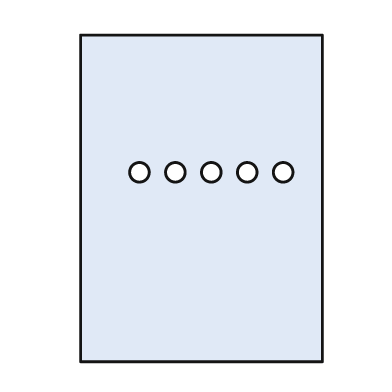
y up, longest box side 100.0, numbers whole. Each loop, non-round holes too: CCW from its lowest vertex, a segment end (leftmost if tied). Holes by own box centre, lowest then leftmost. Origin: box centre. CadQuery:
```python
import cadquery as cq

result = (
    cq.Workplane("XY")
    .moveTo(-37.0, -50.0)
    .lineTo(37.0, -50.0)
    .lineTo(37.0, 50.0)
    .lineTo(-37.0, 50.0)
    .close()
    .moveTo(-19.0, 8.0)
    .circle(3.0)
    .moveTo(-8.0, 8.0)
    .circle(3.0)
    .moveTo(3.0, 8.0)
    .circle(3.0)
    .moveTo(14.0, 8.0)
    .circle(3.0)
    .moveTo(25.0, 8.0)
    .circle(3.0)
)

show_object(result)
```